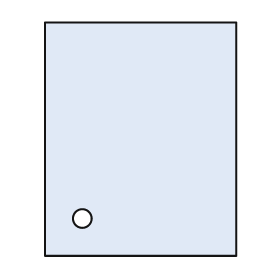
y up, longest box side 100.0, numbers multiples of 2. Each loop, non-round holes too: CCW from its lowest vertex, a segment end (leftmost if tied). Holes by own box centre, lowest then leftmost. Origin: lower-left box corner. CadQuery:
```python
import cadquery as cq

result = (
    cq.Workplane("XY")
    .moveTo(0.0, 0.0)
    .lineTo(82.0, 0.0)
    .lineTo(82.0, 100.0)
    .lineTo(0.0, 100.0)
    .close()
    .moveTo(16.0, 16.0)
    .circle(4.0)
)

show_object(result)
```